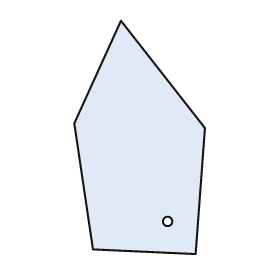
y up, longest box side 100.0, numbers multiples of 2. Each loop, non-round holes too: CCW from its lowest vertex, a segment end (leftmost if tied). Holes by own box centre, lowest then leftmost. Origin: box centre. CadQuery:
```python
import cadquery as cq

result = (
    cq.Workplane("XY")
    .moveTo(24.0, -50.0)
    .lineTo(28.0, 4.0)
    .lineTo(-8.0, 50.0)
    .lineTo(-28.0, 6.0)
    .lineTo(-20.0, -48.0)
    .close()
    .moveTo(12.0, -36.0)
    .circle(2.0)
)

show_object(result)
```